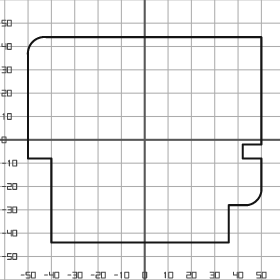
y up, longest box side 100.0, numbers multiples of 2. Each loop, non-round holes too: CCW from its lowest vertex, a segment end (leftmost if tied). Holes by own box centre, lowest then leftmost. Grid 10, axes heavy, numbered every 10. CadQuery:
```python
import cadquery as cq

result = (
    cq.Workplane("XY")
    .moveTo(-40.0, -44.0)
    .lineTo(36.0, -44.0)
    .lineTo(36.0, -28.0)
    .lineTo(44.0, -28.0)
    .threePointArc((48.0, -26.0), (50.0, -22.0))
    .lineTo(50.0, -8.0)
    .lineTo(42.0, -8.0)
    .lineTo(42.0, -2.0)
    .lineTo(50.0, -2.0)
    .lineTo(50.0, 44.0)
    .lineTo(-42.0, 44.0)
    .threePointArc((-48.0, 42.0), (-50.0, 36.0))
    .lineTo(-50.0, -8.0)
    .lineTo(-40.0, -8.0)
    .close()
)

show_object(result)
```